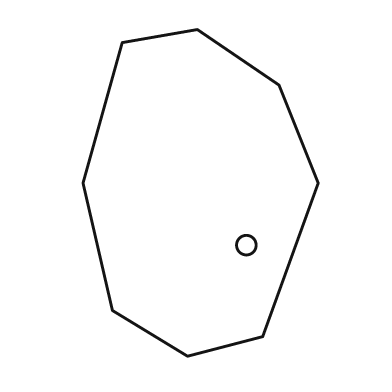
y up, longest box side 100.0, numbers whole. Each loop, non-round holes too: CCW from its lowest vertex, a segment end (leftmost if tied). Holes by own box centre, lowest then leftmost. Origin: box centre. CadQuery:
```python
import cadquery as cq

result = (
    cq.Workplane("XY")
    .moveTo(-4.0, -50.0)
    .lineTo(19.0, -44.0)
    .lineTo(36.0, 3.0)
    .lineTo(24.0, 33.0)
    .lineTo(-1.0, 50.0)
    .lineTo(-24.0, 46.0)
    .lineTo(-36.0, 3.0)
    .lineTo(-27.0, -36.0)
    .close()
    .moveTo(14.0, -16.0)
    .circle(3.0)
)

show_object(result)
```